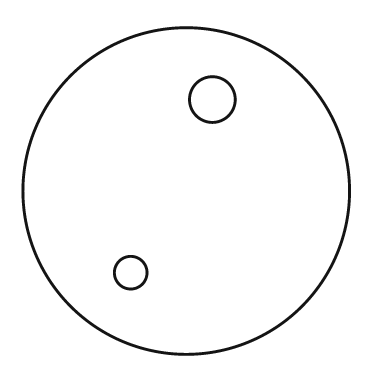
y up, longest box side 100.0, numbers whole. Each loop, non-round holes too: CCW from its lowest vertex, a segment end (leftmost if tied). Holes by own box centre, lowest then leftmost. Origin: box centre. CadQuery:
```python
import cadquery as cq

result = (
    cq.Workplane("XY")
    .moveTo(0.0, 0.0)
    .circle(50.0)
    .moveTo(-17.0, -25.0)
    .circle(5.0)
    .moveTo(8.0, 28.0)
    .circle(7.0)
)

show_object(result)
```